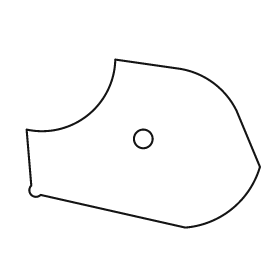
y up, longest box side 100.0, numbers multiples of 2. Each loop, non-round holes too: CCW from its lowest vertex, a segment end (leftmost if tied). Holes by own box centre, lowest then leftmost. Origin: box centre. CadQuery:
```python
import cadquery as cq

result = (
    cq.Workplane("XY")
    .moveTo(18.0, -36.0)
    .threePointArc((38.0, -28.0), (50.0, -10.0))
    .lineTo(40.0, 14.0)
    .threePointArc((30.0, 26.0), (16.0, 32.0))
    .lineTo(-12.0, 36.0)
    .threePointArc((-24.0, 12.0), (-50.0, 6.0))
    .lineTo(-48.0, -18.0)
    .threePointArc((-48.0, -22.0), (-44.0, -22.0))
    .close()
    .moveTo(0.0, 2.0)
    .circle(4.0)
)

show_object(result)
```